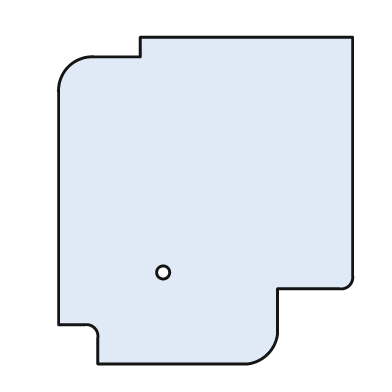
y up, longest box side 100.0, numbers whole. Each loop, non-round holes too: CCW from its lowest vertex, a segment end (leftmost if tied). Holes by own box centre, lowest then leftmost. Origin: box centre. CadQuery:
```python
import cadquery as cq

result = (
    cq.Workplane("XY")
    .moveTo(-33.0, -50.0)
    .lineTo(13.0, -50.0)
    .threePointArc((19.0, -47.0), (22.0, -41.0))
    .lineTo(22.0, -27.0)
    .lineTo(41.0, -27.0)
    .threePointArc((44.0, -26.0), (45.0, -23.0))
    .lineTo(45.0, 50.0)
    .lineTo(-20.0, 50.0)
    .lineTo(-20.0, 44.0)
    .lineTo(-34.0, 44.0)
    .threePointArc((-42.0, 41.0), (-45.0, 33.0))
    .lineTo(-45.0, -38.0)
    .lineTo(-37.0, -38.0)
    .threePointArc((-34.0, -39.0), (-33.0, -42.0))
    .close()
    .moveTo(-13.0, -22.0)
    .circle(2.0)
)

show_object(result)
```